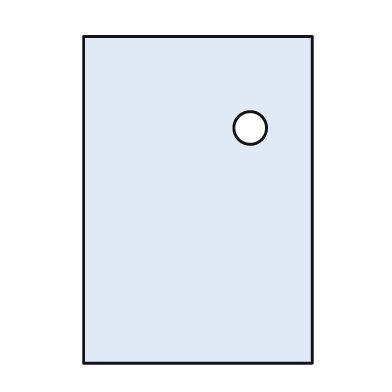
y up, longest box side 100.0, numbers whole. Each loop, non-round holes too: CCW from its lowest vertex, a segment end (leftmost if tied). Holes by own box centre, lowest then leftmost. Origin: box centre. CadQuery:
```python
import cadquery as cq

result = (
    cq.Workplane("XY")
    .moveTo(-35.0, -50.0)
    .lineTo(35.0, -50.0)
    .lineTo(35.0, 50.0)
    .lineTo(-35.0, 50.0)
    .close()
    .moveTo(16.0, 22.0)
    .circle(5.0)
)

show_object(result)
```